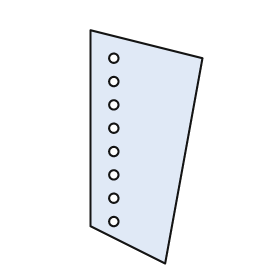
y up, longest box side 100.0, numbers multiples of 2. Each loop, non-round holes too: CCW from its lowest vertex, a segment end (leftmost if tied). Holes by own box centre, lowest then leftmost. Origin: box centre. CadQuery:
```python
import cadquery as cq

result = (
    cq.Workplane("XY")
    .moveTo(8.0, -50.0)
    .lineTo(24.0, 38.0)
    .lineTo(-24.0, 50.0)
    .lineTo(-24.0, -34.0)
    .close()
    .moveTo(-14.0, -32.0)
    .circle(2.0)
    .moveTo(-14.0, -22.0)
    .circle(2.0)
    .moveTo(-14.0, -12.0)
    .circle(2.0)
    .moveTo(-14.0, -2.0)
    .circle(2.0)
    .moveTo(-14.0, 8.0)
    .circle(2.0)
    .moveTo(-14.0, 18.0)
    .circle(2.0)
    .moveTo(-14.0, 28.0)
    .circle(2.0)
    .moveTo(-14.0, 38.0)
    .circle(2.0)
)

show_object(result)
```